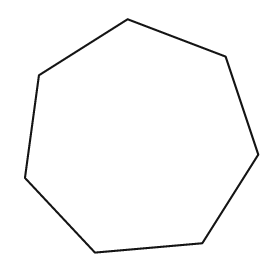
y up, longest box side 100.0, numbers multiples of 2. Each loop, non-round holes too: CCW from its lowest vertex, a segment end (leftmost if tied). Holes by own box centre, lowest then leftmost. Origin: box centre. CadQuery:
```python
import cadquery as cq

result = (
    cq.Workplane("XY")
    .moveTo(-20.0, -50.0)
    .lineTo(26.0, -46.0)
    .lineTo(50.0, -8.0)
    .lineTo(36.0, 34.0)
    .lineTo(-6.0, 50.0)
    .lineTo(-44.0, 26.0)
    .lineTo(-50.0, -18.0)
    .close()
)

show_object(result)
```